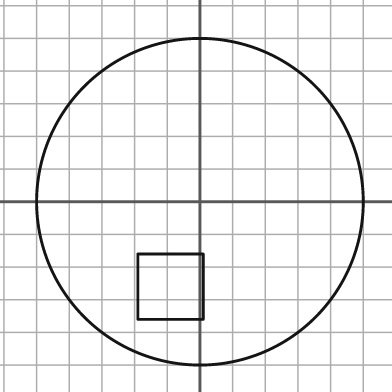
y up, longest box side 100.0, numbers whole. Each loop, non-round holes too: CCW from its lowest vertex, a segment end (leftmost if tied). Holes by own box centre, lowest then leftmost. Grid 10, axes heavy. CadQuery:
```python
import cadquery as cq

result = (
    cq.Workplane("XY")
    .moveTo(0.0, 0.0)
    .circle(50.0)
    .moveTo(-19.0, -36.0)
    .lineTo(1.0, -36.0)
    .lineTo(1.0, -16.0)
    .lineTo(-19.0, -16.0)
    .close()
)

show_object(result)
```